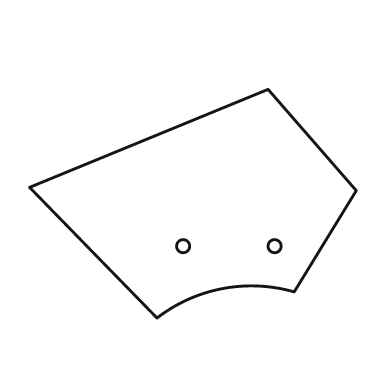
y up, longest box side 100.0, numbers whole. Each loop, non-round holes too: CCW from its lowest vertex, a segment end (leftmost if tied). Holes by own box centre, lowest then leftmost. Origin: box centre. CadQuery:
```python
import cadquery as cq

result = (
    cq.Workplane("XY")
    .moveTo(-11.0, -35.0)
    .threePointArc((9.0, -26.0), (31.0, -27.0))
    .lineTo(50.0, 4.0)
    .lineTo(23.0, 35.0)
    .lineTo(-50.0, 5.0)
    .close()
    .moveTo(-3.0, -13.0)
    .circle(2.0)
    .moveTo(25.0, -13.0)
    .circle(2.0)
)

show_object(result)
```